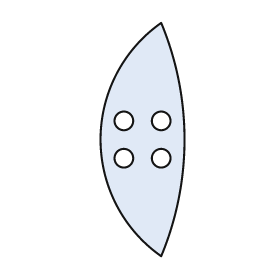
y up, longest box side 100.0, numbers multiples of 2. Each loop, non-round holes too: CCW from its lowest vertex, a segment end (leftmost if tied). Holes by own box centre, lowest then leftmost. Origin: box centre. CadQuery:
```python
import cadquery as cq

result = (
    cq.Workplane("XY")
    .moveTo(8.0, -50.0)
    .threePointArc((18.0, 0.0), (8.0, 50.0))
    .threePointArc((-18.0, 0.0), (8.0, -50.0))
    .close()
    .moveTo(-8.0, -8.0)
    .circle(4.0)
    .moveTo(8.0, -8.0)
    .circle(4.0)
    .moveTo(-8.0, 8.0)
    .circle(4.0)
    .moveTo(8.0, 8.0)
    .circle(4.0)
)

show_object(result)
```